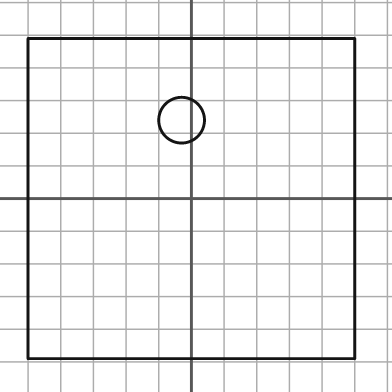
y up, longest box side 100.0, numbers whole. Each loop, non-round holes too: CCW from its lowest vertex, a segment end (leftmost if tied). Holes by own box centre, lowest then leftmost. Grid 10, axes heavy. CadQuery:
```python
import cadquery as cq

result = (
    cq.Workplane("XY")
    .moveTo(-50.0, -49.0)
    .lineTo(50.0, -49.0)
    .lineTo(50.0, 49.0)
    .lineTo(-50.0, 49.0)
    .close()
    .moveTo(-3.0, 24.0)
    .circle(7.0)
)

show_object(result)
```